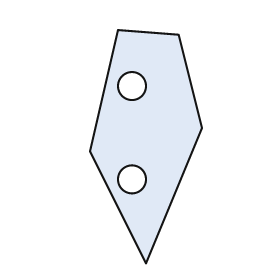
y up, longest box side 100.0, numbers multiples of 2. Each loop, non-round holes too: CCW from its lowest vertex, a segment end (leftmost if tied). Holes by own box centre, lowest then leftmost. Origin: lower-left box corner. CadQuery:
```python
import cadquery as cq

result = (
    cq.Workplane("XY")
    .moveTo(24.0, 0.0)
    .lineTo(48.0, 58.0)
    .lineTo(38.0, 98.0)
    .lineTo(12.0, 100.0)
    .lineTo(0.0, 48.0)
    .close()
    .moveTo(18.0, 36.0)
    .circle(6.0)
    .moveTo(18.0, 76.0)
    .circle(6.0)
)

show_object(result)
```